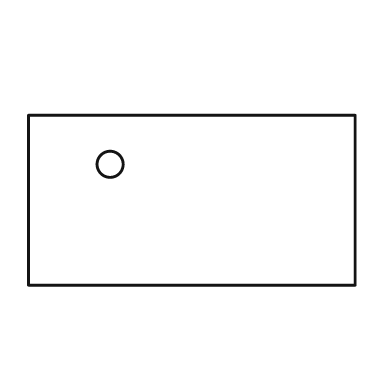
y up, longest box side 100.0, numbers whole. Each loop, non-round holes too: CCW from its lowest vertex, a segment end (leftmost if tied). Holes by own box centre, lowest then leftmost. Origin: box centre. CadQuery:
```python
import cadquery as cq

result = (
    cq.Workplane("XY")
    .moveTo(-50.0, -26.0)
    .lineTo(50.0, -26.0)
    .lineTo(50.0, 26.0)
    .lineTo(-50.0, 26.0)
    .close()
    .moveTo(-25.0, 11.0)
    .circle(4.0)
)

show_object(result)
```